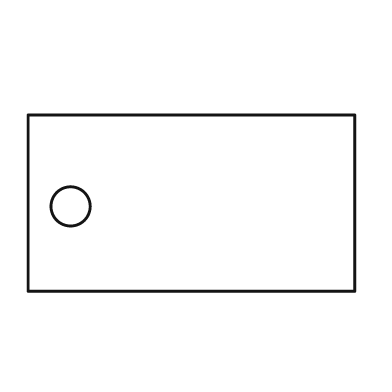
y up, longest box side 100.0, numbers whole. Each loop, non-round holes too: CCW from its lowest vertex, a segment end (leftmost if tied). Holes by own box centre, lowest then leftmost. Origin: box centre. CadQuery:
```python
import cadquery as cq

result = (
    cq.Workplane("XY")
    .moveTo(-50.0, -27.0)
    .lineTo(50.0, -27.0)
    .lineTo(50.0, 27.0)
    .lineTo(-50.0, 27.0)
    .close()
    .moveTo(-37.0, -1.0)
    .circle(6.0)
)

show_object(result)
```